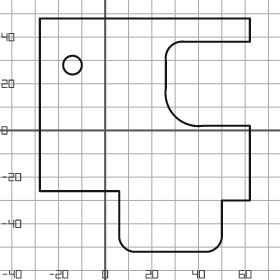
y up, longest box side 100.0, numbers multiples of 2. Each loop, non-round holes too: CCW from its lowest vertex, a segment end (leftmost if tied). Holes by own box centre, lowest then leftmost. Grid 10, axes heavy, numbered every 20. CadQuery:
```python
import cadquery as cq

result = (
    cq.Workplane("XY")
    .moveTo(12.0, -52.0)
    .lineTo(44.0, -52.0)
    .threePointArc((48.0, -50.0), (50.0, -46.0))
    .lineTo(50.0, -30.0)
    .lineTo(62.0, -30.0)
    .lineTo(62.0, 2.0)
    .lineTo(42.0, 2.0)
    .threePointArc((30.0, 6.0), (26.0, 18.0))
    .lineTo(26.0, 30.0)
    .threePointArc((28.0, 36.0), (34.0, 38.0))
    .lineTo(62.0, 38.0)
    .lineTo(62.0, 48.0)
    .lineTo(-28.0, 48.0)
    .lineTo(-28.0, -26.0)
    .lineTo(6.0, -26.0)
    .lineTo(6.0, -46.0)
    .threePointArc((8.0, -50.0), (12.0, -52.0))
    .close()
    .moveTo(-14.0, 28.0)
    .circle(4.0)
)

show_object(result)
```